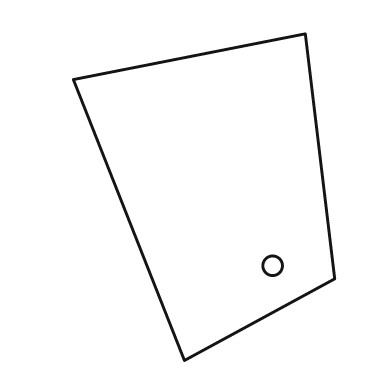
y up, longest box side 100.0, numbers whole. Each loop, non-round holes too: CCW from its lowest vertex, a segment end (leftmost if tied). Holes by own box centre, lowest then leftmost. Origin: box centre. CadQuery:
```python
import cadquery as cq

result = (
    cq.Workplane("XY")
    .moveTo(-6.0, -50.0)
    .lineTo(40.0, -25.0)
    .lineTo(31.0, 50.0)
    .lineTo(-40.0, 36.0)
    .close()
    .moveTo(21.0, -21.0)
    .circle(3.0)
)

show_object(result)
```